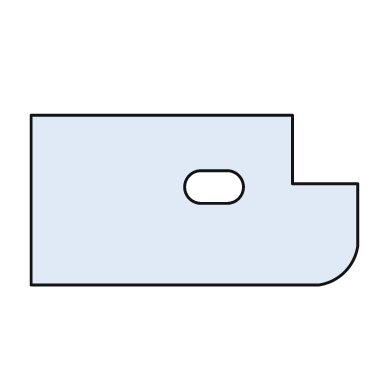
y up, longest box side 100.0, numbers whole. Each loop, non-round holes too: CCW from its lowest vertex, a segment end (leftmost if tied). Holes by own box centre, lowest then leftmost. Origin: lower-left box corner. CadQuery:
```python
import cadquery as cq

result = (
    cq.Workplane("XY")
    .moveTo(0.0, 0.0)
    .lineTo(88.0, 0.0)
    .threePointArc((96.0, 4.0), (100.0, 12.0))
    .lineTo(100.0, 31.0)
    .lineTo(80.0, 31.0)
    .lineTo(80.0, 52.0)
    .lineTo(0.0, 52.0)
    .close()
    .moveTo(52.0, 25.0)
    .lineTo(60.0, 25.0)
    .threePointArc((65.0, 30.0), (60.0, 35.0))
    .lineTo(52.0, 35.0)
    .threePointArc((47.0, 30.0), (52.0, 25.0))
    .close()
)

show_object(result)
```